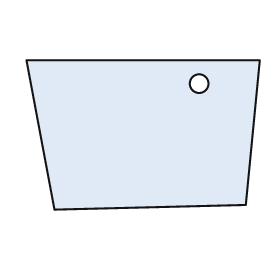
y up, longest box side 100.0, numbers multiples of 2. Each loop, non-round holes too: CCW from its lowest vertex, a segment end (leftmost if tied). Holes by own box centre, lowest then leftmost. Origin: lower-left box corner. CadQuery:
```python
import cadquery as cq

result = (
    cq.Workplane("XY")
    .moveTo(12.0, 0.0)
    .lineTo(94.0, 2.0)
    .lineTo(100.0, 64.0)
    .lineTo(0.0, 64.0)
    .close()
    .moveTo(74.0, 54.0)
    .circle(4.0)
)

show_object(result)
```